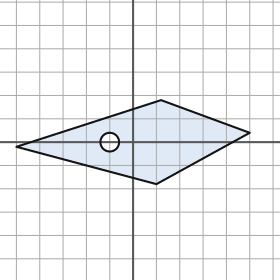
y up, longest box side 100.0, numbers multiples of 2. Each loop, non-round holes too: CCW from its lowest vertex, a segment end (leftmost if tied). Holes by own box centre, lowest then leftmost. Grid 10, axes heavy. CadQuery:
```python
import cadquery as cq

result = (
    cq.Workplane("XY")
    .moveTo(10.0, -18.0)
    .lineTo(50.0, 4.0)
    .lineTo(12.0, 18.0)
    .lineTo(-50.0, -2.0)
    .close()
    .moveTo(-10.0, 0.0)
    .circle(4.0)
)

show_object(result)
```